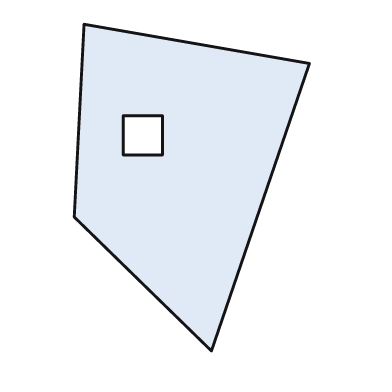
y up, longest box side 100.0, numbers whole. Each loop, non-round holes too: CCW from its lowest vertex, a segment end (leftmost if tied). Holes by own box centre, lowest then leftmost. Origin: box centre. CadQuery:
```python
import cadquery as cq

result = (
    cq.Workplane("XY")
    .moveTo(6.0, -50.0)
    .lineTo(36.0, 38.0)
    .lineTo(-33.0, 50.0)
    .lineTo(-36.0, -9.0)
    .close()
    .moveTo(-21.0, 10.0)
    .lineTo(-9.0, 10.0)
    .lineTo(-9.0, 22.0)
    .lineTo(-21.0, 22.0)
    .close()
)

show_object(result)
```